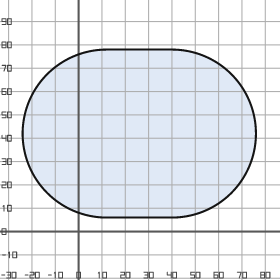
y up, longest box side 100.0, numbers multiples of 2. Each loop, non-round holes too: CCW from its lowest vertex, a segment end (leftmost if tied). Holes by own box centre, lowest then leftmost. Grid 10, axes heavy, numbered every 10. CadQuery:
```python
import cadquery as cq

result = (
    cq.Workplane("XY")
    .moveTo(12.0, 6.0)
    .lineTo(40.0, 6.0)
    .threePointArc((76.0, 42.0), (40.0, 78.0))
    .lineTo(12.0, 78.0)
    .threePointArc((-24.0, 42.0), (12.0, 6.0))
    .close()
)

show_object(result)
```